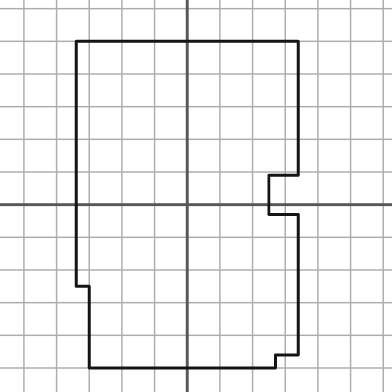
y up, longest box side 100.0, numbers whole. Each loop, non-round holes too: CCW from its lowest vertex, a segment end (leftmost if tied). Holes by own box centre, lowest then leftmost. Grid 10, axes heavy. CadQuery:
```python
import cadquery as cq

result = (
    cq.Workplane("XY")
    .moveTo(-30.0, -50.0)
    .lineTo(27.0, -50.0)
    .lineTo(27.0, -46.0)
    .lineTo(34.0, -46.0)
    .lineTo(34.0, -3.0)
    .lineTo(25.0, -3.0)
    .lineTo(25.0, 9.0)
    .lineTo(34.0, 9.0)
    .lineTo(34.0, 50.0)
    .lineTo(-34.0, 50.0)
    .lineTo(-34.0, -25.0)
    .lineTo(-30.0, -25.0)
    .close()
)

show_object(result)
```